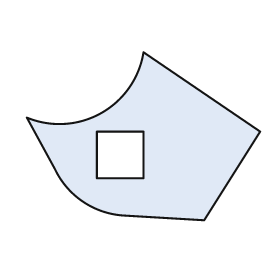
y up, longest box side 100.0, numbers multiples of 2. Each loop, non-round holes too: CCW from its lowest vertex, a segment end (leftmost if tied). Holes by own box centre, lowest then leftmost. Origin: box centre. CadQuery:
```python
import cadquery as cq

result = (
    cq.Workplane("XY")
    .moveTo(26.0, -36.0)
    .lineTo(50.0, 2.0)
    .lineTo(0.0, 36.0)
    .threePointArc((-18.0, 10.0), (-50.0, 8.0))
    .lineTo(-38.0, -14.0)
    .threePointArc((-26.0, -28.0), (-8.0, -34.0))
    .close()
    .moveTo(-20.0, -18.0)
    .lineTo(0.0, -18.0)
    .lineTo(0.0, 2.0)
    .lineTo(-20.0, 2.0)
    .close()
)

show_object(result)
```